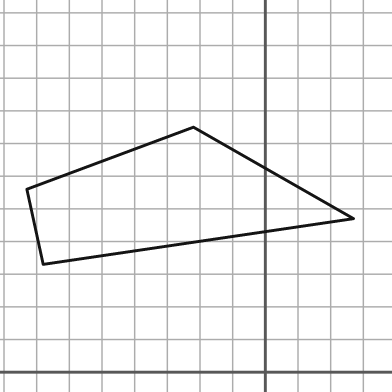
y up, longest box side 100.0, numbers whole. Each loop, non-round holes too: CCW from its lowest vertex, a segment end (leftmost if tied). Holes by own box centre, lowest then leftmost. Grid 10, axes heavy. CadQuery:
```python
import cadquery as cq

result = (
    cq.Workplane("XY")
    .moveTo(-68.0, 33.0)
    .lineTo(27.0, 47.0)
    .lineTo(-22.0, 75.0)
    .lineTo(-73.0, 56.0)
    .close()
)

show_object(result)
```